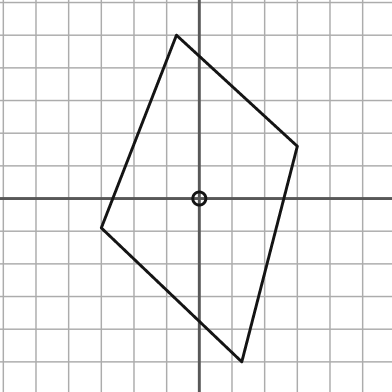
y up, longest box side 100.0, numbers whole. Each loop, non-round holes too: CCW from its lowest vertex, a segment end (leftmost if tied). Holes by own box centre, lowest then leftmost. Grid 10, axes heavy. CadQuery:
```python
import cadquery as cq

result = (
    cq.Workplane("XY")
    .moveTo(13.0, -50.0)
    .lineTo(30.0, 16.0)
    .lineTo(-7.0, 50.0)
    .lineTo(-30.0, -9.0)
    .close()
    .moveTo(0.0, 0.0)
    .circle(2.0)
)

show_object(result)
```